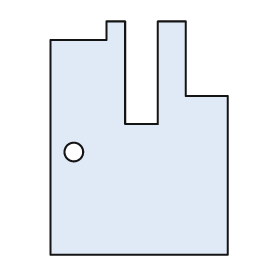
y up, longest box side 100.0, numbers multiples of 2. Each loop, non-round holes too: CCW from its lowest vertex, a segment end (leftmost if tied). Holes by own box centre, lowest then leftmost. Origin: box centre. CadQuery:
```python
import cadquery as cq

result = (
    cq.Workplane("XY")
    .moveTo(-38.0, -50.0)
    .lineTo(38.0, -50.0)
    .lineTo(38.0, 18.0)
    .lineTo(20.0, 18.0)
    .lineTo(20.0, 50.0)
    .lineTo(8.0, 50.0)
    .lineTo(8.0, 6.0)
    .lineTo(-6.0, 6.0)
    .lineTo(-6.0, 50.0)
    .lineTo(-14.0, 50.0)
    .lineTo(-14.0, 42.0)
    .lineTo(-38.0, 42.0)
    .close()
    .moveTo(-28.0, -6.0)
    .circle(4.0)
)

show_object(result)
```